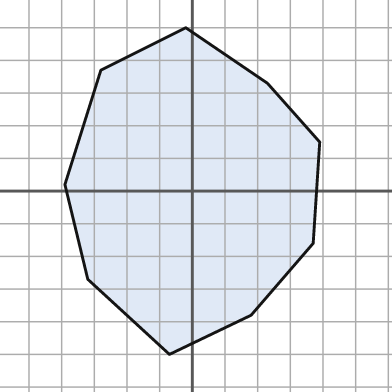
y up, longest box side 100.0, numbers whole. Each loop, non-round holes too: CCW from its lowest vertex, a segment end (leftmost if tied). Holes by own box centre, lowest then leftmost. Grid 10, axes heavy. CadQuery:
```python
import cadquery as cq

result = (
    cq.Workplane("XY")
    .moveTo(-7.0, -50.0)
    .lineTo(18.0, -38.0)
    .lineTo(37.0, -16.0)
    .lineTo(39.0, 15.0)
    .lineTo(23.0, 33.0)
    .lineTo(-2.0, 50.0)
    .lineTo(-28.0, 37.0)
    .lineTo(-39.0, 2.0)
    .lineTo(-32.0, -27.0)
    .close()
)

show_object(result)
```